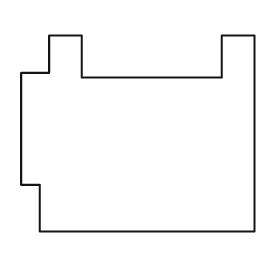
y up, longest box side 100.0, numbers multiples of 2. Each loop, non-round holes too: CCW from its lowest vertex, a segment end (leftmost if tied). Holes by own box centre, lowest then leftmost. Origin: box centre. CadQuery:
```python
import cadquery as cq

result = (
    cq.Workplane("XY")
    .moveTo(-42.0, -42.0)
    .lineTo(50.0, -42.0)
    .lineTo(50.0, 42.0)
    .lineTo(36.0, 42.0)
    .lineTo(36.0, 24.0)
    .lineTo(-24.0, 24.0)
    .lineTo(-24.0, 42.0)
    .lineTo(-38.0, 42.0)
    .lineTo(-38.0, 26.0)
    .lineTo(-50.0, 26.0)
    .lineTo(-50.0, -22.0)
    .lineTo(-42.0, -22.0)
    .close()
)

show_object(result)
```